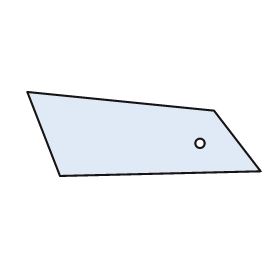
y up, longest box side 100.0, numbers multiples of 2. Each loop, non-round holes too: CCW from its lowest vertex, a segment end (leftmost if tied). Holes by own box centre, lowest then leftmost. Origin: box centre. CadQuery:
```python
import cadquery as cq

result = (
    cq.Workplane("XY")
    .moveTo(-36.0, -18.0)
    .lineTo(50.0, -16.0)
    .lineTo(30.0, 10.0)
    .lineTo(-50.0, 18.0)
    .close()
    .moveTo(24.0, -4.0)
    .circle(2.0)
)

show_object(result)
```